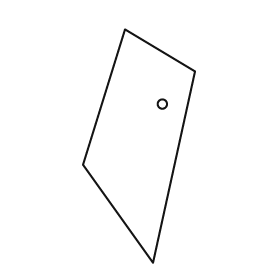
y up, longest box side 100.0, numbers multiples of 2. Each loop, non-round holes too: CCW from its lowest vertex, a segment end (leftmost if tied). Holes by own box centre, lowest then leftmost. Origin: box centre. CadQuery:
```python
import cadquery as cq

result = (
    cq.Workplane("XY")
    .moveTo(6.0, -50.0)
    .lineTo(24.0, 32.0)
    .lineTo(-6.0, 50.0)
    .lineTo(-24.0, -8.0)
    .close()
    .moveTo(10.0, 18.0)
    .circle(2.0)
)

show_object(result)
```